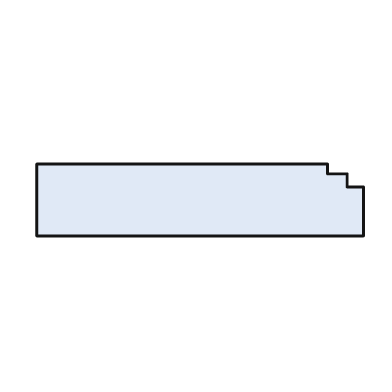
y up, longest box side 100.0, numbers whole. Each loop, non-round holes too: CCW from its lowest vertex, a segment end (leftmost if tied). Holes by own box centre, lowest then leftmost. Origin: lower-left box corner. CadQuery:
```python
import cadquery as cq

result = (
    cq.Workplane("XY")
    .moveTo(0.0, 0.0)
    .lineTo(100.0, 0.0)
    .lineTo(100.0, 15.0)
    .lineTo(95.0, 15.0)
    .lineTo(95.0, 19.0)
    .lineTo(89.0, 19.0)
    .lineTo(89.0, 22.0)
    .lineTo(0.0, 22.0)
    .close()
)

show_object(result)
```